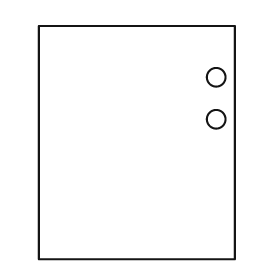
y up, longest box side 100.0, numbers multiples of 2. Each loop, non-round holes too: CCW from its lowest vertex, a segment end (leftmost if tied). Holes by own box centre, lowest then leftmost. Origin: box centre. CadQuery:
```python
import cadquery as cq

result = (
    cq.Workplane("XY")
    .moveTo(-42.0, -50.0)
    .lineTo(42.0, -50.0)
    .lineTo(42.0, 50.0)
    .lineTo(-42.0, 50.0)
    .close()
    .moveTo(34.0, 10.0)
    .circle(4.0)
    .moveTo(34.0, 28.0)
    .circle(4.0)
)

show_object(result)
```